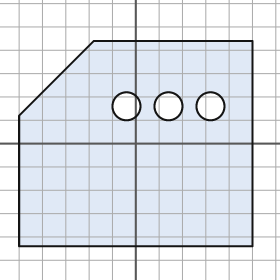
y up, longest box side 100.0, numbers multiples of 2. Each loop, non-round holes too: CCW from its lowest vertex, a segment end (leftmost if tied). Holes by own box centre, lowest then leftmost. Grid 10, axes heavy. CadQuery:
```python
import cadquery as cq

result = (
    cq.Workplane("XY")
    .moveTo(-50.0, -44.0)
    .lineTo(50.0, -44.0)
    .lineTo(50.0, 44.0)
    .lineTo(-18.0, 44.0)
    .lineTo(-50.0, 12.0)
    .close()
    .moveTo(-4.0, 16.0)
    .circle(6.0)
    .moveTo(14.0, 16.0)
    .circle(6.0)
    .moveTo(32.0, 16.0)
    .circle(6.0)
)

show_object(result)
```